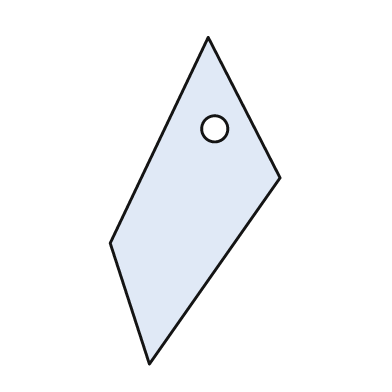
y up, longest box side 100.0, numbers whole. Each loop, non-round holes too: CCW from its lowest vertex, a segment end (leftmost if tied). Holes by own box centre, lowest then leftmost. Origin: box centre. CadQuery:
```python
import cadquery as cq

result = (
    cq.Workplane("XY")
    .moveTo(-14.0, -50.0)
    .lineTo(26.0, 7.0)
    .lineTo(4.0, 50.0)
    .lineTo(-26.0, -13.0)
    .close()
    .moveTo(6.0, 22.0)
    .circle(4.0)
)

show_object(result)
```